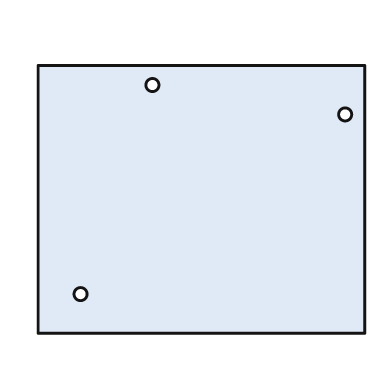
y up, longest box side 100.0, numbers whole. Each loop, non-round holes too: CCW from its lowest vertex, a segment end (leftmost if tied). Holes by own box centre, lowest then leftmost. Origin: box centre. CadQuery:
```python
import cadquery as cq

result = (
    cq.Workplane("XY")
    .moveTo(-50.0, -41.0)
    .lineTo(50.0, -41.0)
    .lineTo(50.0, 41.0)
    .lineTo(-50.0, 41.0)
    .close()
    .moveTo(-37.0, -29.0)
    .circle(2.0)
    .moveTo(44.0, 26.0)
    .circle(2.0)
    .moveTo(-15.0, 35.0)
    .circle(2.0)
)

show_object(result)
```